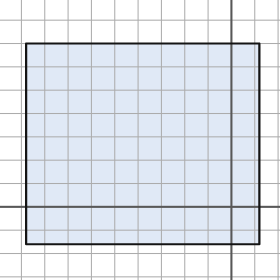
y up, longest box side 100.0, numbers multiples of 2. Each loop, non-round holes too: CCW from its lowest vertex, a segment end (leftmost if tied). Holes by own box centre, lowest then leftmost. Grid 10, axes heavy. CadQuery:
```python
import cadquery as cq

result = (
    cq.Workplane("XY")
    .moveTo(-88.0, -16.0)
    .lineTo(12.0, -16.0)
    .lineTo(12.0, 70.0)
    .lineTo(-88.0, 70.0)
    .close()
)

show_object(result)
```